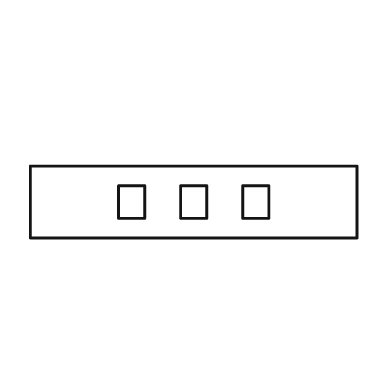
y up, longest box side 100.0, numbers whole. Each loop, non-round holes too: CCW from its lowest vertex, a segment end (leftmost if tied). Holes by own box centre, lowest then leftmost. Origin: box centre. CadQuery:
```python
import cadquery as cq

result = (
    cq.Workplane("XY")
    .moveTo(-50.0, -11.0)
    .lineTo(50.0, -11.0)
    .lineTo(50.0, 11.0)
    .lineTo(-50.0, 11.0)
    .close()
    .moveTo(-23.0, -5.0)
    .lineTo(-15.0, -5.0)
    .lineTo(-15.0, 5.0)
    .lineTo(-23.0, 5.0)
    .close()
    .moveTo(-4.0, -5.0)
    .lineTo(4.0, -5.0)
    .lineTo(4.0, 5.0)
    .lineTo(-4.0, 5.0)
    .close()
    .moveTo(15.0, -5.0)
    .lineTo(23.0, -5.0)
    .lineTo(23.0, 5.0)
    .lineTo(15.0, 5.0)
    .close()
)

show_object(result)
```